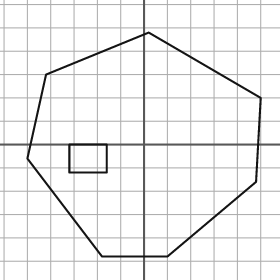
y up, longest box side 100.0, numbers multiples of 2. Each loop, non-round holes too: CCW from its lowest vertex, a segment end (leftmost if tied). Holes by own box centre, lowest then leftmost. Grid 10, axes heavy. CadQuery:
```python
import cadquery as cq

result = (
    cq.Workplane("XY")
    .moveTo(-18.0, -48.0)
    .lineTo(10.0, -48.0)
    .lineTo(48.0, -16.0)
    .lineTo(50.0, 20.0)
    .lineTo(2.0, 48.0)
    .lineTo(-42.0, 30.0)
    .lineTo(-50.0, -6.0)
    .close()
    .moveTo(-32.0, -12.0)
    .lineTo(-16.0, -12.0)
    .lineTo(-16.0, 0.0)
    .lineTo(-32.0, 0.0)
    .close()
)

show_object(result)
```